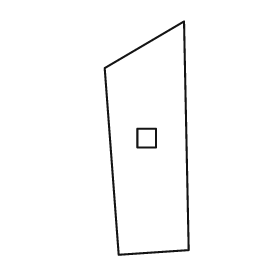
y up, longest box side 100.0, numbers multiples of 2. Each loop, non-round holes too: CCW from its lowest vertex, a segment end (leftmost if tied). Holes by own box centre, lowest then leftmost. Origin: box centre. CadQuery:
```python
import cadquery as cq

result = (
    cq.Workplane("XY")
    .moveTo(-12.0, -50.0)
    .lineTo(18.0, -48.0)
    .lineTo(16.0, 50.0)
    .lineTo(-18.0, 30.0)
    .close()
    .moveTo(-4.0, -4.0)
    .lineTo(4.0, -4.0)
    .lineTo(4.0, 4.0)
    .lineTo(-4.0, 4.0)
    .close()
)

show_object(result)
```